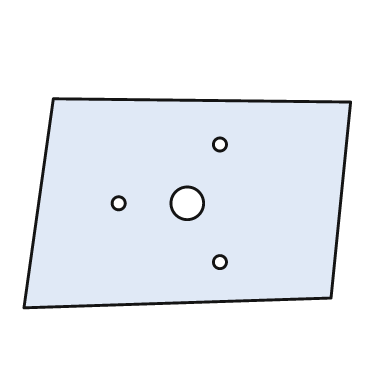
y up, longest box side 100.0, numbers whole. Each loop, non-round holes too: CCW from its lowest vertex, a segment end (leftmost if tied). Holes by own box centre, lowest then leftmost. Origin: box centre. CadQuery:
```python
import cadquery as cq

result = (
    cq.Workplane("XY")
    .moveTo(-50.0, -32.0)
    .lineTo(44.0, -29.0)
    .lineTo(50.0, 31.0)
    .lineTo(-41.0, 32.0)
    .close()
    .moveTo(10.0, -18.0)
    .circle(2.0)
    .moveTo(-21.0, 0.0)
    .circle(2.0)
    .moveTo(0.0, 0.0)
    .circle(5.0)
    .moveTo(10.0, 18.0)
    .circle(2.0)
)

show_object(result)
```